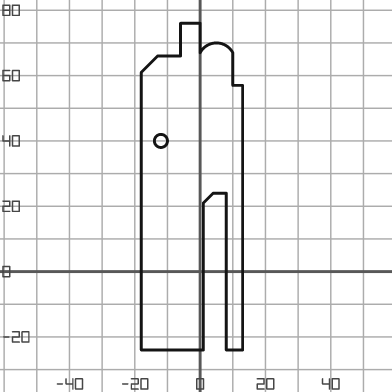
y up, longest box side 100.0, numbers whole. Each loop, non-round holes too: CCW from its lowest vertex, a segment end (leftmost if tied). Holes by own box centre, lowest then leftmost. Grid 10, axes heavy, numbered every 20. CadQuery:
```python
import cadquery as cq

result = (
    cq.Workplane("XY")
    .moveTo(-18.0, -24.0)
    .lineTo(1.0, -24.0)
    .lineTo(1.0, 21.0)
    .lineTo(4.0, 24.0)
    .lineTo(8.0, 24.0)
    .lineTo(8.0, -24.0)
    .lineTo(13.0, -24.0)
    .lineTo(13.0, 57.0)
    .lineTo(10.0, 57.0)
    .lineTo(10.0, 67.0)
    .threePointArc((5.0, 70.0), (0.0, 67.0))
    .lineTo(0.0, 76.0)
    .lineTo(-6.0, 76.0)
    .lineTo(-6.0, 66.0)
    .lineTo(-13.0, 66.0)
    .lineTo(-18.0, 61.0)
    .close()
    .moveTo(-12.0, 40.0)
    .circle(2.0)
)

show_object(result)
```